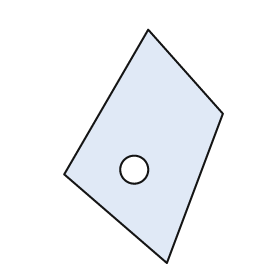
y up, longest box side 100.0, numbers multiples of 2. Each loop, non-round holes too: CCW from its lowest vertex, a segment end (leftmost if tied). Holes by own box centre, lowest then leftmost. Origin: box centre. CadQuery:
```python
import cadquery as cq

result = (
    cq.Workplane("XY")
    .moveTo(10.0, -50.0)
    .lineTo(34.0, 14.0)
    .lineTo(2.0, 50.0)
    .lineTo(-34.0, -12.0)
    .close()
    .moveTo(-4.0, -10.0)
    .circle(6.0)
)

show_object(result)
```